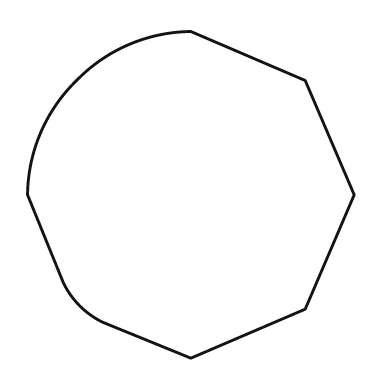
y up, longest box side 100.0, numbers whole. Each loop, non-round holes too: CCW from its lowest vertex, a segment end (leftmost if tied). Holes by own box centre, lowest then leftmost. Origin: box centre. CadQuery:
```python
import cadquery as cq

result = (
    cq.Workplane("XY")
    .moveTo(0.0, -50.0)
    .lineTo(35.0, -35.0)
    .lineTo(50.0, 0.0)
    .lineTo(35.0, 35.0)
    .lineTo(0.0, 50.0)
    .threePointArc((-19.0, 46.0), (-35.0, 35.0))
    .threePointArc((-46.0, 19.0), (-50.0, 0.0))
    .lineTo(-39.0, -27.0)
    .threePointArc((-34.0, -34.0), (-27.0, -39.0))
    .close()
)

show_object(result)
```